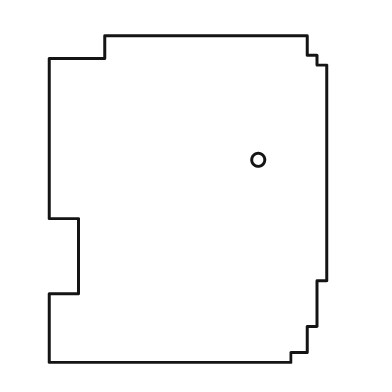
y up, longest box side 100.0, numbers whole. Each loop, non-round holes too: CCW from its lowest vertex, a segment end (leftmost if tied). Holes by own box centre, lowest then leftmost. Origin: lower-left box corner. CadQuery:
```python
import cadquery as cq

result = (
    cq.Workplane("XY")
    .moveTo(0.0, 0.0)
    .lineTo(74.0, 0.0)
    .lineTo(74.0, 3.0)
    .lineTo(79.0, 3.0)
    .lineTo(79.0, 11.0)
    .lineTo(82.0, 11.0)
    .lineTo(82.0, 25.0)
    .lineTo(85.0, 25.0)
    .lineTo(85.0, 91.0)
    .lineTo(82.0, 91.0)
    .lineTo(82.0, 94.0)
    .lineTo(79.0, 94.0)
    .lineTo(79.0, 100.0)
    .lineTo(17.0, 100.0)
    .lineTo(17.0, 93.0)
    .lineTo(0.0, 93.0)
    .lineTo(0.0, 44.0)
    .lineTo(9.0, 44.0)
    .lineTo(9.0, 21.0)
    .lineTo(0.0, 21.0)
    .close()
    .moveTo(64.0, 62.0)
    .circle(2.0)
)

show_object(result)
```